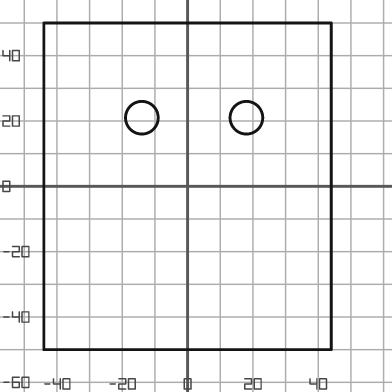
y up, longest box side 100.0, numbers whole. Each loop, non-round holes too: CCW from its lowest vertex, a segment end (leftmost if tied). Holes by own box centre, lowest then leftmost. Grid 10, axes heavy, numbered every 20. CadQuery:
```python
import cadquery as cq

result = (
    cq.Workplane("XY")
    .moveTo(-44.0, -50.0)
    .lineTo(44.0, -50.0)
    .lineTo(44.0, 50.0)
    .lineTo(-44.0, 50.0)
    .close()
    .moveTo(-14.0, 21.0)
    .circle(5.0)
    .moveTo(18.0, 21.0)
    .circle(5.0)
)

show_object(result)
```